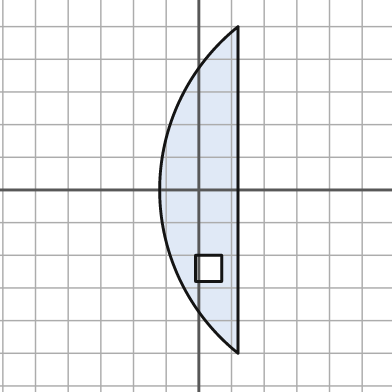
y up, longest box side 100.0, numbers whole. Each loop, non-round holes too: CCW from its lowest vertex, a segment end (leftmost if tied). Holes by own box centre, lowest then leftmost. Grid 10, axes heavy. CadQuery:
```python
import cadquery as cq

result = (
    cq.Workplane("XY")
    .moveTo(12.0, -50.0)
    .lineTo(12.0, 50.0)
    .threePointArc((-12.0, 0.0), (12.0, -50.0))
    .close()
    .moveTo(-1.0, -28.0)
    .lineTo(7.0, -28.0)
    .lineTo(7.0, -20.0)
    .lineTo(-1.0, -20.0)
    .close()
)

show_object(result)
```